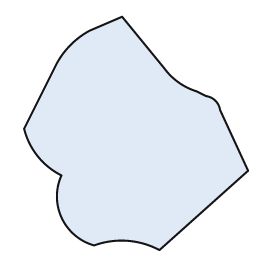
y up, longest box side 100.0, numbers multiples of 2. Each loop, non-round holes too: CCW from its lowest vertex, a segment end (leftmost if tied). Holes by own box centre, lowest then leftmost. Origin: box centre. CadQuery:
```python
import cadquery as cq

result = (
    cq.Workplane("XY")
    .moveTo(10.0, -50.0)
    .lineTo(48.0, -16.0)
    .lineTo(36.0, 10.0)
    .threePointArc((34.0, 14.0), (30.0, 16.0))
    .lineTo(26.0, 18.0)
    .threePointArc((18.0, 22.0), (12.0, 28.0))
    .lineTo(-6.0, 50.0)
    .lineTo(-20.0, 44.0)
    .threePointArc((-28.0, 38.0), (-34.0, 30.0))
    .lineTo(-48.0, 2.0)
    .threePointArc((-42.0, -10.0), (-32.0, -18.0))
    .threePointArc((-32.0, -36.0), (-18.0, -48.0))
    .threePointArc((-4.0, -46.0), (10.0, -50.0))
    .close()
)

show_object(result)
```